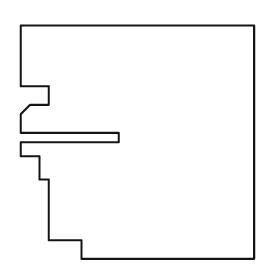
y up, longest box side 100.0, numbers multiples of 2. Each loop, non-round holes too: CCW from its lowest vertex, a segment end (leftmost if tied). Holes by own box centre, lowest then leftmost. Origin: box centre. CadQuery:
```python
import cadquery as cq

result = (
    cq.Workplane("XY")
    .moveTo(-24.0, -50.0)
    .lineTo(50.0, -50.0)
    .lineTo(50.0, 50.0)
    .lineTo(-50.0, 50.0)
    .lineTo(-50.0, 24.0)
    .lineTo(-38.0, 24.0)
    .lineTo(-38.0, 16.0)
    .lineTo(-46.0, 16.0)
    .lineTo(-50.0, 12.0)
    .lineTo(-50.0, 4.0)
    .lineTo(-8.0, 4.0)
    .lineTo(-8.0, 0.0)
    .lineTo(-50.0, 0.0)
    .lineTo(-50.0, -6.0)
    .lineTo(-42.0, -6.0)
    .lineTo(-42.0, -16.0)
    .lineTo(-38.0, -16.0)
    .lineTo(-38.0, -42.0)
    .lineTo(-24.0, -42.0)
    .close()
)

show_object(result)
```